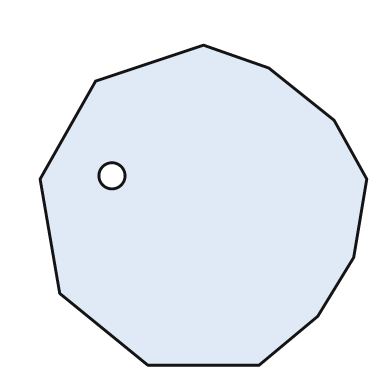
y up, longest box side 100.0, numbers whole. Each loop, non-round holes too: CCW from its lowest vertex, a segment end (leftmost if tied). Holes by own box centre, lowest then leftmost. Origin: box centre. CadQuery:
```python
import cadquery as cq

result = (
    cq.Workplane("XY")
    .moveTo(-17.0, -49.0)
    .lineTo(17.0, -49.0)
    .lineTo(35.0, -34.0)
    .lineTo(46.0, -16.0)
    .lineTo(50.0, 8.0)
    .lineTo(40.0, 26.0)
    .lineTo(20.0, 42.0)
    .lineTo(0.0, 49.0)
    .lineTo(-33.0, 38.0)
    .lineTo(-50.0, 8.0)
    .lineTo(-44.0, -27.0)
    .close()
    .moveTo(-28.0, 9.0)
    .circle(4.0)
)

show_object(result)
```